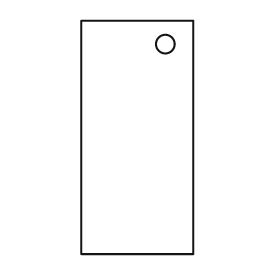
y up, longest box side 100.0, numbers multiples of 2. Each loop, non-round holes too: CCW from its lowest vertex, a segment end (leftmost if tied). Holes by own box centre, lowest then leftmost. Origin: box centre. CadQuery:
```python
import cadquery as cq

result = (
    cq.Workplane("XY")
    .moveTo(-24.0, -50.0)
    .lineTo(24.0, -50.0)
    .lineTo(24.0, 50.0)
    .lineTo(-24.0, 50.0)
    .close()
    .moveTo(12.0, 40.0)
    .circle(4.0)
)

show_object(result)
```